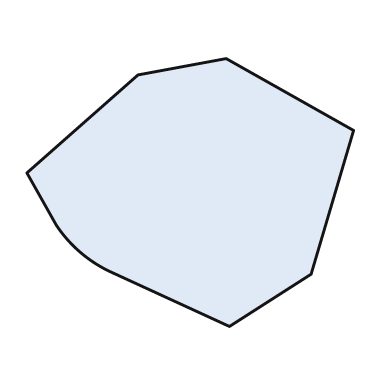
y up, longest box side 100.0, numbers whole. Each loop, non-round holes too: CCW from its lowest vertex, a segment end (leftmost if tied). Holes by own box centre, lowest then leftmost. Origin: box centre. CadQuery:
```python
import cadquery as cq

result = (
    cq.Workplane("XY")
    .moveTo(12.0, -41.0)
    .lineTo(37.0, -25.0)
    .lineTo(50.0, 19.0)
    .lineTo(11.0, 41.0)
    .lineTo(-16.0, 36.0)
    .lineTo(-50.0, 6.0)
    .lineTo(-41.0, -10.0)
    .threePointArc((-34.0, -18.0), (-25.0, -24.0))
    .close()
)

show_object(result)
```